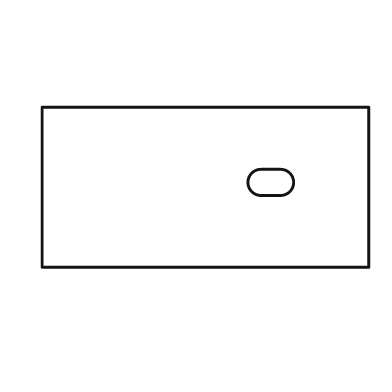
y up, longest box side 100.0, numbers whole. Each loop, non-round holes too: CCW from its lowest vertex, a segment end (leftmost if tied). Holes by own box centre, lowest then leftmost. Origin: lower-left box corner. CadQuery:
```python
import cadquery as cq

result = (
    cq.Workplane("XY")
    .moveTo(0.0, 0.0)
    .lineTo(100.0, 0.0)
    .lineTo(100.0, 49.0)
    .lineTo(0.0, 49.0)
    .close()
    .moveTo(67.0, 22.0)
    .lineTo(73.0, 22.0)
    .threePointArc((77.0, 26.0), (73.0, 30.0))
    .lineTo(67.0, 30.0)
    .threePointArc((63.0, 26.0), (67.0, 22.0))
    .close()
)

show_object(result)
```